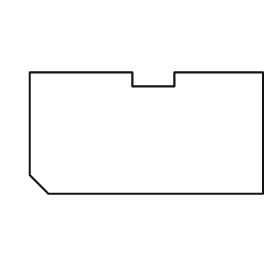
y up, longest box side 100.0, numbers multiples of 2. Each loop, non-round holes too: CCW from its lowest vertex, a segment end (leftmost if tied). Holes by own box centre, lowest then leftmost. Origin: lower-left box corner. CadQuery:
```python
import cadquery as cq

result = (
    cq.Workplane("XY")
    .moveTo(8.0, 0.0)
    .lineTo(100.0, 0.0)
    .lineTo(100.0, 52.0)
    .lineTo(62.0, 52.0)
    .lineTo(62.0, 46.0)
    .lineTo(44.0, 46.0)
    .lineTo(44.0, 52.0)
    .lineTo(0.0, 52.0)
    .lineTo(0.0, 8.0)
    .close()
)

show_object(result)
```